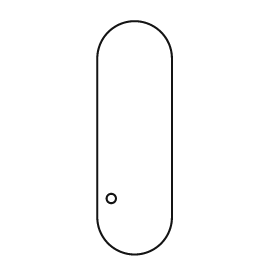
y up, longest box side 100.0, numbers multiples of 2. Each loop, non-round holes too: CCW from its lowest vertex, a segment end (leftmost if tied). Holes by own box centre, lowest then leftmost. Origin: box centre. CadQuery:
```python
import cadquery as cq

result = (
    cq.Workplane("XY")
    .moveTo(-16.0, -34.0)
    .threePointArc((0.0, -50.0), (16.0, -34.0))
    .lineTo(16.0, 34.0)
    .threePointArc((0.0, 50.0), (-16.0, 34.0))
    .close()
    .moveTo(-10.0, -26.0)
    .circle(2.0)
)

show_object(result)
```